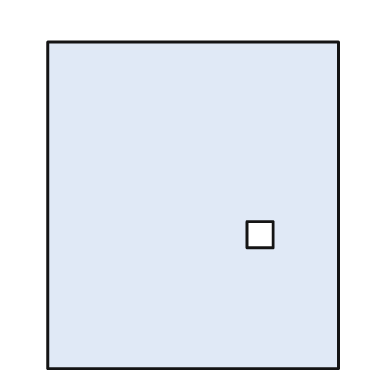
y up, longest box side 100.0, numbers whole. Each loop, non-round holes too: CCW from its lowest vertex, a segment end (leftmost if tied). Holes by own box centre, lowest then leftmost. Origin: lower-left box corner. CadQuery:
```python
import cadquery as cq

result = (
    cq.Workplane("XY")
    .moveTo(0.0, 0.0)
    .lineTo(89.0, 0.0)
    .lineTo(89.0, 100.0)
    .lineTo(0.0, 100.0)
    .close()
    .moveTo(61.0, 37.0)
    .lineTo(69.0, 37.0)
    .lineTo(69.0, 45.0)
    .lineTo(61.0, 45.0)
    .close()
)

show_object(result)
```